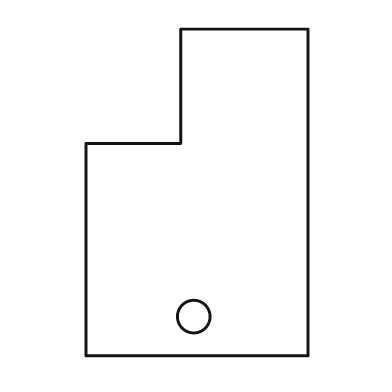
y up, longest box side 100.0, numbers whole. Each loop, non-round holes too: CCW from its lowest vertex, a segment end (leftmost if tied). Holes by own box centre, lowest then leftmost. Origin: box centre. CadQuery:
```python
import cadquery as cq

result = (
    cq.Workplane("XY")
    .moveTo(-34.0, -50.0)
    .lineTo(34.0, -50.0)
    .lineTo(34.0, 50.0)
    .lineTo(-5.0, 50.0)
    .lineTo(-5.0, 15.0)
    .lineTo(-34.0, 15.0)
    .close()
    .moveTo(-1.0, -38.0)
    .circle(5.0)
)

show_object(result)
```